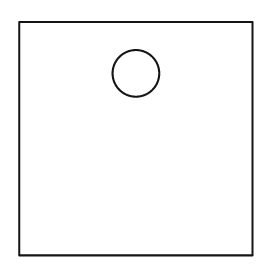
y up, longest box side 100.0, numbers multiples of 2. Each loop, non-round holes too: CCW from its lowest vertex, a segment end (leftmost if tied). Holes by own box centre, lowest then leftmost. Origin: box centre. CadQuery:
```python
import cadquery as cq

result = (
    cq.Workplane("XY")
    .moveTo(-50.0, -50.0)
    .lineTo(50.0, -50.0)
    .lineTo(50.0, 50.0)
    .lineTo(-50.0, 50.0)
    .close()
    .moveTo(0.0, 28.0)
    .circle(10.0)
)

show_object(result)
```